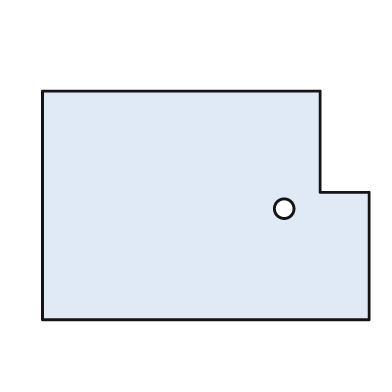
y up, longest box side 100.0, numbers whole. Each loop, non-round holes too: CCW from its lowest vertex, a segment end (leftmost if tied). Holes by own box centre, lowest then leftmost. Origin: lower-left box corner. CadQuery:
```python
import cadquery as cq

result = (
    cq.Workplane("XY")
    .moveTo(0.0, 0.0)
    .lineTo(100.0, 0.0)
    .lineTo(100.0, 39.0)
    .lineTo(85.0, 39.0)
    .lineTo(85.0, 70.0)
    .lineTo(0.0, 70.0)
    .close()
    .moveTo(74.0, 34.0)
    .circle(3.0)
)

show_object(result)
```